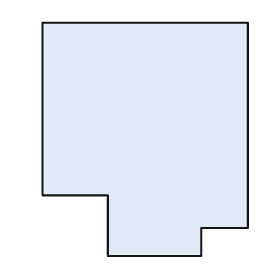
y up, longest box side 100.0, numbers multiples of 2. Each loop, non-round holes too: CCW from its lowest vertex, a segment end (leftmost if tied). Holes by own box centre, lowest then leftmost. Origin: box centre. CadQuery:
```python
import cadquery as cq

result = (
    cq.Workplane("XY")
    .moveTo(-16.0, -50.0)
    .lineTo(24.0, -50.0)
    .lineTo(24.0, -38.0)
    .lineTo(44.0, -38.0)
    .lineTo(44.0, 50.0)
    .lineTo(-44.0, 50.0)
    .lineTo(-44.0, -24.0)
    .lineTo(-16.0, -24.0)
    .close()
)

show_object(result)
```